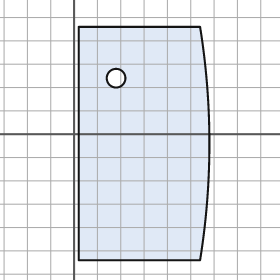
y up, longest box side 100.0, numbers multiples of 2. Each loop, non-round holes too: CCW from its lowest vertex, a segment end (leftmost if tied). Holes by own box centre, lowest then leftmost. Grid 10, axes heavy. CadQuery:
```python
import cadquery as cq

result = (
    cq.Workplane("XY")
    .moveTo(2.0, -54.0)
    .lineTo(54.0, -54.0)
    .threePointArc((58.0, -4.0), (54.0, 46.0))
    .lineTo(2.0, 46.0)
    .close()
    .moveTo(18.0, 24.0)
    .circle(4.0)
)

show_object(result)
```